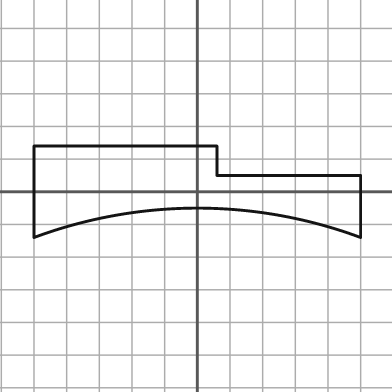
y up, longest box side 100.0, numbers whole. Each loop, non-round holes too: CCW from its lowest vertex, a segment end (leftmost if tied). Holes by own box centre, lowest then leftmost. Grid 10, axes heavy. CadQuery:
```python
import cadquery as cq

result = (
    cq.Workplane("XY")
    .moveTo(-50.0, -14.0)
    .threePointArc((0.0, -5.0), (50.0, -14.0))
    .lineTo(50.0, 5.0)
    .lineTo(6.0, 5.0)
    .lineTo(6.0, 14.0)
    .lineTo(-50.0, 14.0)
    .close()
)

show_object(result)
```